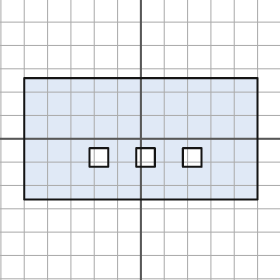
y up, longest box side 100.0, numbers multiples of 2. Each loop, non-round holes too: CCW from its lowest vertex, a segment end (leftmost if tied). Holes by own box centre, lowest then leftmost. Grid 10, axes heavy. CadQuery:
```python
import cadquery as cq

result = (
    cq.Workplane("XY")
    .moveTo(-50.0, -26.0)
    .lineTo(50.0, -26.0)
    .lineTo(50.0, 26.0)
    .lineTo(-50.0, 26.0)
    .close()
    .moveTo(-22.0, -12.0)
    .lineTo(-14.0, -12.0)
    .lineTo(-14.0, -4.0)
    .lineTo(-22.0, -4.0)
    .close()
    .moveTo(-2.0, -12.0)
    .lineTo(6.0, -12.0)
    .lineTo(6.0, -4.0)
    .lineTo(-2.0, -4.0)
    .close()
    .moveTo(18.0, -12.0)
    .lineTo(26.0, -12.0)
    .lineTo(26.0, -4.0)
    .lineTo(18.0, -4.0)
    .close()
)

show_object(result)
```